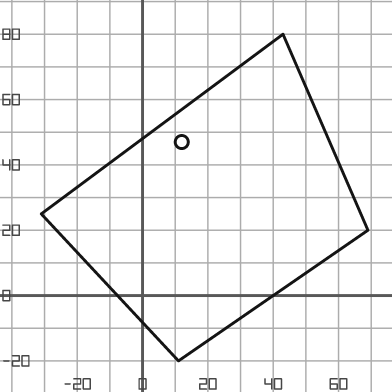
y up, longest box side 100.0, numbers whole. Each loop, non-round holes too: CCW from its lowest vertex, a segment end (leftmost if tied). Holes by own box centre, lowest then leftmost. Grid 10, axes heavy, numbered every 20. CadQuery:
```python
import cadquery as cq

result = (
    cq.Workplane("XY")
    .moveTo(11.0, -20.0)
    .lineTo(69.0, 20.0)
    .lineTo(43.0, 80.0)
    .lineTo(-31.0, 25.0)
    .close()
    .moveTo(12.0, 47.0)
    .circle(2.0)
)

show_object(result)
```